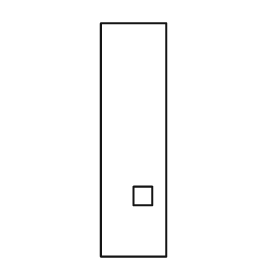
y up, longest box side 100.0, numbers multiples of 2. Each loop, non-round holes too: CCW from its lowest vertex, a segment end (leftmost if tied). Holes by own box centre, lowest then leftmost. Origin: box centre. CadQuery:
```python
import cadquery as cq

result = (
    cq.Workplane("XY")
    .moveTo(-14.0, -50.0)
    .lineTo(14.0, -50.0)
    .lineTo(14.0, 50.0)
    .lineTo(-14.0, 50.0)
    .close()
    .moveTo(0.0, -28.0)
    .lineTo(8.0, -28.0)
    .lineTo(8.0, -20.0)
    .lineTo(0.0, -20.0)
    .close()
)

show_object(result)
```